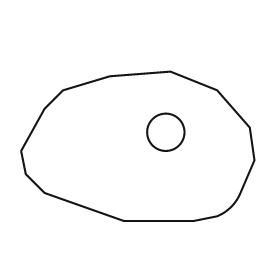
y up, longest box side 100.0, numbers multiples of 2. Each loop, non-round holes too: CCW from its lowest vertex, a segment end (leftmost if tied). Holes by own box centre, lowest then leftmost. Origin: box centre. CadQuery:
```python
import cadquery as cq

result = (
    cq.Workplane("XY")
    .moveTo(-6.0, -32.0)
    .lineTo(24.0, -32.0)
    .lineTo(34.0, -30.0)
    .threePointArc((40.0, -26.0), (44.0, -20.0))
    .lineTo(50.0, -6.0)
    .lineTo(48.0, 8.0)
    .lineTo(34.0, 24.0)
    .lineTo(14.0, 32.0)
    .lineTo(-12.0, 30.0)
    .lineTo(-32.0, 24.0)
    .lineTo(-40.0, 16.0)
    .lineTo(-50.0, -2.0)
    .lineTo(-48.0, -12.0)
    .lineTo(-40.0, -20.0)
    .close()
    .moveTo(12.0, 6.0)
    .circle(8.0)
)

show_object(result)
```